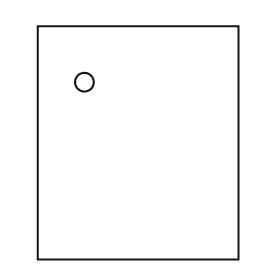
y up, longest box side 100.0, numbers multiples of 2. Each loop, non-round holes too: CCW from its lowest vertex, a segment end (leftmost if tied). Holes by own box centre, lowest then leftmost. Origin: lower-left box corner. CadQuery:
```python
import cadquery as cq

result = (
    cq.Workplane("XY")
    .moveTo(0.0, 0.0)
    .lineTo(86.0, 0.0)
    .lineTo(86.0, 100.0)
    .lineTo(0.0, 100.0)
    .close()
    .moveTo(20.0, 76.0)
    .circle(4.0)
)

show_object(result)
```